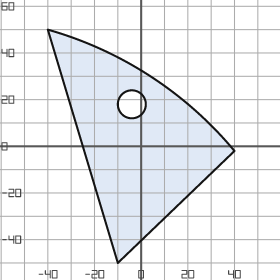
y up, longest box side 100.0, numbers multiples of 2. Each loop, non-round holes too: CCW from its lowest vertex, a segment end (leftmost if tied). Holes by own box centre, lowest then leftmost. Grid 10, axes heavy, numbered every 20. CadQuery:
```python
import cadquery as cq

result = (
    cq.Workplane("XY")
    .moveTo(-10.0, -50.0)
    .lineTo(40.0, -2.0)
    .threePointArc((4.0, 30.0), (-40.0, 50.0))
    .close()
    .moveTo(-4.0, 18.0)
    .circle(6.0)
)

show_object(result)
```